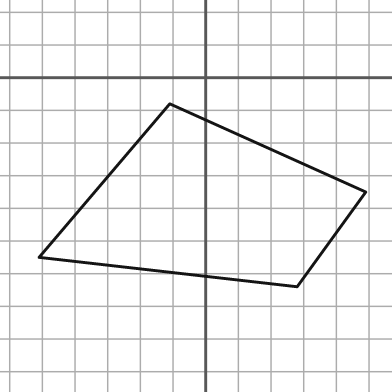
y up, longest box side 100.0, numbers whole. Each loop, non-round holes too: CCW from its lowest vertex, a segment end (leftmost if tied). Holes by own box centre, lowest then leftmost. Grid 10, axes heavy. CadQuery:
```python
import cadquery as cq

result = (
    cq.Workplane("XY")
    .moveTo(28.0, -64.0)
    .lineTo(49.0, -35.0)
    .lineTo(-11.0, -8.0)
    .lineTo(-51.0, -55.0)
    .close()
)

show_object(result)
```